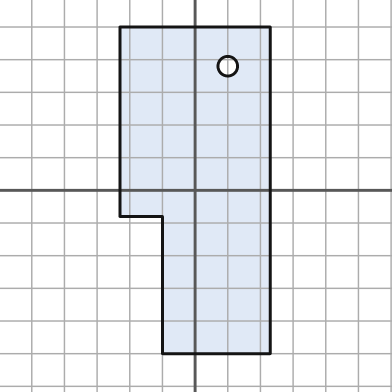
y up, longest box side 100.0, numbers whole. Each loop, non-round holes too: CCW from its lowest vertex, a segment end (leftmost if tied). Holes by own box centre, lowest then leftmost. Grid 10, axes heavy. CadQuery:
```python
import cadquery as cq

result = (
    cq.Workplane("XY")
    .moveTo(-10.0, -50.0)
    .lineTo(23.0, -50.0)
    .lineTo(23.0, 50.0)
    .lineTo(-23.0, 50.0)
    .lineTo(-23.0, -8.0)
    .lineTo(-10.0, -8.0)
    .close()
    .moveTo(10.0, 38.0)
    .circle(3.0)
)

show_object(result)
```